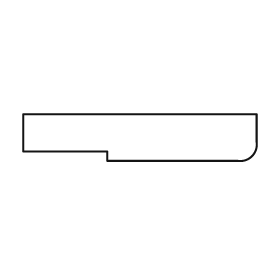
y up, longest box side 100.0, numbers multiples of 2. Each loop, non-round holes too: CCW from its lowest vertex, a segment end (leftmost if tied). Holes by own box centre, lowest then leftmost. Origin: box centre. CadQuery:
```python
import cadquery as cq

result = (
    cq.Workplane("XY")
    .moveTo(-14.0, -10.0)
    .lineTo(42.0, -10.0)
    .threePointArc((48.0, -8.0), (50.0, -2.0))
    .lineTo(50.0, 10.0)
    .lineTo(-50.0, 10.0)
    .lineTo(-50.0, -6.0)
    .lineTo(-14.0, -6.0)
    .close()
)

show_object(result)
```